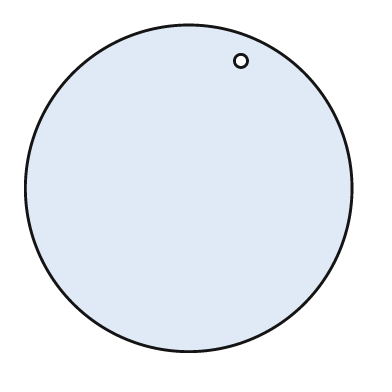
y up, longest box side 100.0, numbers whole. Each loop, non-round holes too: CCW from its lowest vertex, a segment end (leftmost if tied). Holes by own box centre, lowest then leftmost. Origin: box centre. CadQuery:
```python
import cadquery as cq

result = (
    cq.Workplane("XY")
    .moveTo(0.0, 0.0)
    .circle(50.0)
    .moveTo(16.0, 39.0)
    .circle(2.0)
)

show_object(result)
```